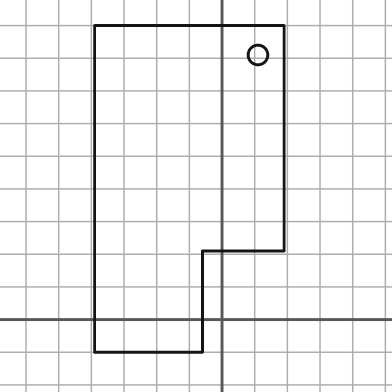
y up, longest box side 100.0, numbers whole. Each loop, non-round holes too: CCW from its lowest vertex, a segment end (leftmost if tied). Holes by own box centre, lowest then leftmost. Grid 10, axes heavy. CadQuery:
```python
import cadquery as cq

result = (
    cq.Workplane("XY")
    .moveTo(-39.0, -10.0)
    .lineTo(-6.0, -10.0)
    .lineTo(-6.0, 21.0)
    .lineTo(19.0, 21.0)
    .lineTo(19.0, 90.0)
    .lineTo(-39.0, 90.0)
    .close()
    .moveTo(11.0, 81.0)
    .circle(3.0)
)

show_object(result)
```